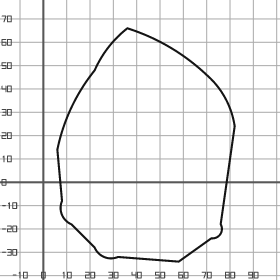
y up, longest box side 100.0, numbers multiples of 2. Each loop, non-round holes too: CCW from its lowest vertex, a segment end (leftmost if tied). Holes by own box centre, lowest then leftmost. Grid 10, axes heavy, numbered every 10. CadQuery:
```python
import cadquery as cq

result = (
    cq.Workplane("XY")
    .moveTo(58.0, -34.0)
    .lineTo(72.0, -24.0)
    .threePointArc((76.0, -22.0), (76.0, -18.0))
    .lineTo(82.0, 24.0)
    .threePointArc((78.0, 36.0), (70.0, 46.0))
    .threePointArc((54.0, 58.0), (36.0, 66.0))
    .threePointArc((28.0, 58.0), (22.0, 48.0))
    .threePointArc((12.0, 32.0), (6.0, 14.0))
    .lineTo(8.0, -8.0)
    .threePointArc((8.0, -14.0), (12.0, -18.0))
    .lineTo(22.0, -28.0)
    .threePointArc((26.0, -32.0), (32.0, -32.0))
    .close()
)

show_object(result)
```